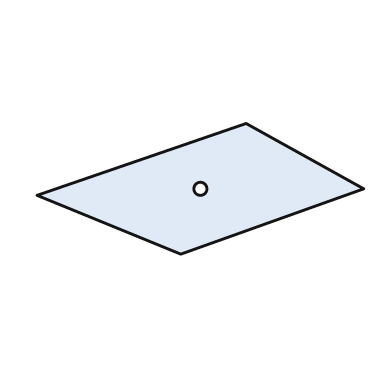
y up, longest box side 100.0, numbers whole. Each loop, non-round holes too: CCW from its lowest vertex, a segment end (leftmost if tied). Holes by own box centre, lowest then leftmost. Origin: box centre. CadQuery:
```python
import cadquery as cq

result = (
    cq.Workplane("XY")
    .moveTo(-6.0, -20.0)
    .lineTo(50.0, 0.0)
    .lineTo(14.0, 20.0)
    .lineTo(-50.0, -2.0)
    .close()
    .moveTo(0.0, 0.0)
    .circle(2.0)
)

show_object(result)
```